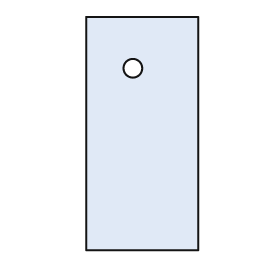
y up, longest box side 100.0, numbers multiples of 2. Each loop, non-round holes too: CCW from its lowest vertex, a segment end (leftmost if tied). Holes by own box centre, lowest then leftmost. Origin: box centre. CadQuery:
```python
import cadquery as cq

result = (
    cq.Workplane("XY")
    .moveTo(-24.0, -50.0)
    .lineTo(24.0, -50.0)
    .lineTo(24.0, 50.0)
    .lineTo(-24.0, 50.0)
    .close()
    .moveTo(-4.0, 28.0)
    .circle(4.0)
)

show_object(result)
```